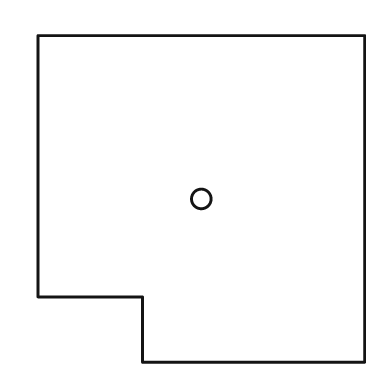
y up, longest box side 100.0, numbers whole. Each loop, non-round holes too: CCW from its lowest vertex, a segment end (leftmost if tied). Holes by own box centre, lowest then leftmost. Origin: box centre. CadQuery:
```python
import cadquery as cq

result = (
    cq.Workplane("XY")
    .moveTo(-18.0, -50.0)
    .lineTo(50.0, -50.0)
    .lineTo(50.0, 50.0)
    .lineTo(-50.0, 50.0)
    .lineTo(-50.0, -30.0)
    .lineTo(-18.0, -30.0)
    .close()
    .moveTo(0.0, 0.0)
    .circle(3.0)
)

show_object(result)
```